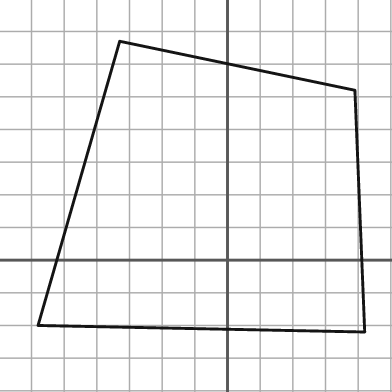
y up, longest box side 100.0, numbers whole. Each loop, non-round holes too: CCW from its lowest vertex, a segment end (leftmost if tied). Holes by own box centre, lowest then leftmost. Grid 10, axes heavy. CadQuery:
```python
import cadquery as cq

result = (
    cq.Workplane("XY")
    .moveTo(42.0, -22.0)
    .lineTo(39.0, 52.0)
    .lineTo(-33.0, 67.0)
    .lineTo(-58.0, -20.0)
    .close()
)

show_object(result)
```